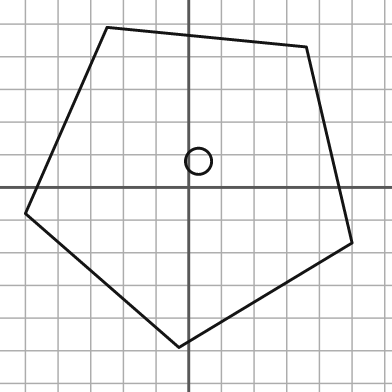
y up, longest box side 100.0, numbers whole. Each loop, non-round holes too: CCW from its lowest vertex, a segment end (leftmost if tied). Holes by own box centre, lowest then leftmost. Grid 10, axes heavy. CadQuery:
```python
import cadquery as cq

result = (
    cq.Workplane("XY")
    .moveTo(-3.0, -49.0)
    .lineTo(50.0, -17.0)
    .lineTo(36.0, 43.0)
    .lineTo(-25.0, 49.0)
    .lineTo(-50.0, -8.0)
    .close()
    .moveTo(3.0, 8.0)
    .circle(4.0)
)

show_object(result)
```